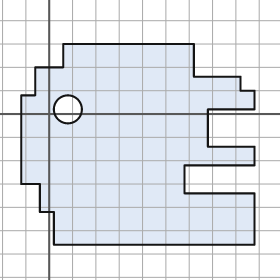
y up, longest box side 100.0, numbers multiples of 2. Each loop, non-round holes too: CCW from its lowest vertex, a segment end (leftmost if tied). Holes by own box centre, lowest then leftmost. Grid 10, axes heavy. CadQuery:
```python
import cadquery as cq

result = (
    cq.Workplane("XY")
    .moveTo(2.0, -56.0)
    .lineTo(88.0, -56.0)
    .lineTo(88.0, -34.0)
    .lineTo(58.0, -34.0)
    .lineTo(58.0, -22.0)
    .lineTo(88.0, -22.0)
    .lineTo(88.0, -14.0)
    .lineTo(68.0, -14.0)
    .lineTo(68.0, 2.0)
    .lineTo(88.0, 2.0)
    .lineTo(88.0, 10.0)
    .lineTo(82.0, 10.0)
    .lineTo(82.0, 16.0)
    .lineTo(62.0, 16.0)
    .lineTo(62.0, 30.0)
    .lineTo(6.0, 30.0)
    .lineTo(6.0, 20.0)
    .lineTo(-6.0, 20.0)
    .lineTo(-6.0, 8.0)
    .lineTo(-12.0, 8.0)
    .lineTo(-12.0, -30.0)
    .lineTo(-4.0, -30.0)
    .lineTo(-4.0, -42.0)
    .lineTo(2.0, -42.0)
    .close()
    .moveTo(8.0, 2.0)
    .circle(6.0)
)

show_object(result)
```